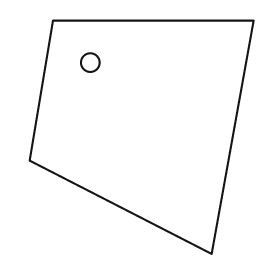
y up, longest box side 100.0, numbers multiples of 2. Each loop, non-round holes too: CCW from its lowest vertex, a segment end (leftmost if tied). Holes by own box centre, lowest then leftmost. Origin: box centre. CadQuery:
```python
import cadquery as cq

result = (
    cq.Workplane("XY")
    .moveTo(30.0, -50.0)
    .lineTo(48.0, 50.0)
    .lineTo(-38.0, 50.0)
    .lineTo(-48.0, -10.0)
    .close()
    .moveTo(-22.0, 32.0)
    .circle(4.0)
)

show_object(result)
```